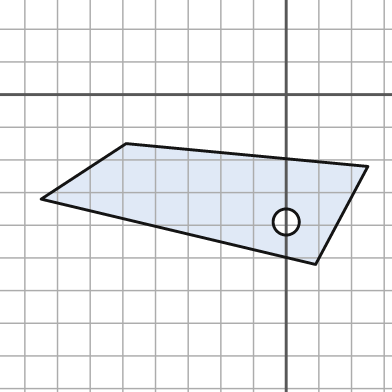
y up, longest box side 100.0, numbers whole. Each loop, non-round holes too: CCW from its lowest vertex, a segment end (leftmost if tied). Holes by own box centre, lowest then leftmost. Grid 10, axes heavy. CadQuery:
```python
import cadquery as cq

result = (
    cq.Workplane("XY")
    .moveTo(9.0, -52.0)
    .lineTo(25.0, -22.0)
    .lineTo(-49.0, -15.0)
    .lineTo(-75.0, -32.0)
    .close()
    .moveTo(0.0, -39.0)
    .circle(4.0)
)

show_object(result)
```